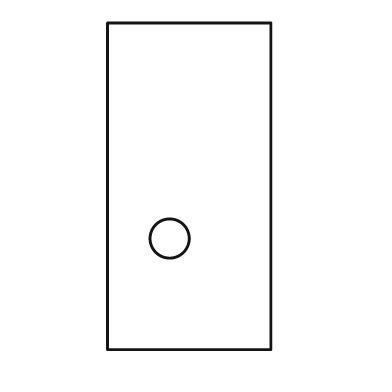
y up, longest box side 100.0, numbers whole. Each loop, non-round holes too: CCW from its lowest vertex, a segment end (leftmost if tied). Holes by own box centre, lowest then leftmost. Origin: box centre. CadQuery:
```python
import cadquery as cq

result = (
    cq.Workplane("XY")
    .moveTo(-25.0, -50.0)
    .lineTo(25.0, -50.0)
    .lineTo(25.0, 50.0)
    .lineTo(-25.0, 50.0)
    .close()
    .moveTo(-6.0, -16.0)
    .circle(6.0)
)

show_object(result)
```